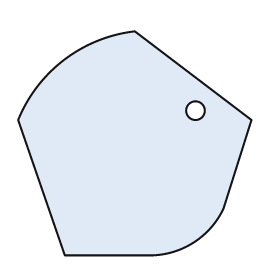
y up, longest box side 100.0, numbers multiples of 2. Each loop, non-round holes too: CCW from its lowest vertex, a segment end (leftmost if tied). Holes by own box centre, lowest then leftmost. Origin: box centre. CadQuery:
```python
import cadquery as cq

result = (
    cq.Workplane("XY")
    .moveTo(-30.0, -48.0)
    .lineTo(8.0, -48.0)
    .threePointArc((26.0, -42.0), (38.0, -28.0))
    .lineTo(50.0, 10.0)
    .lineTo(0.0, 48.0)
    .threePointArc((-30.0, 36.0), (-50.0, 10.0))
    .close()
    .moveTo(26.0, 14.0)
    .circle(4.0)
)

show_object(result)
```